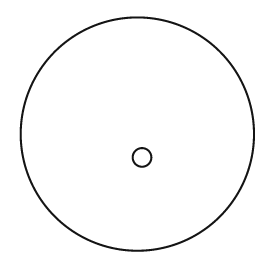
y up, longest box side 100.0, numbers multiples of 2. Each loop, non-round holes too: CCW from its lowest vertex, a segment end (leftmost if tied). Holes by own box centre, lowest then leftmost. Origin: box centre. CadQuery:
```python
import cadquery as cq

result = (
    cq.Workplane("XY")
    .moveTo(0.0, 0.0)
    .circle(50.0)
    .moveTo(2.0, -10.0)
    .circle(4.0)
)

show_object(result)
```